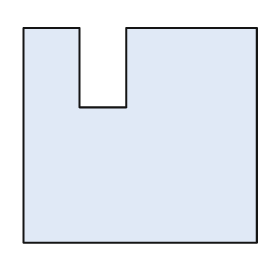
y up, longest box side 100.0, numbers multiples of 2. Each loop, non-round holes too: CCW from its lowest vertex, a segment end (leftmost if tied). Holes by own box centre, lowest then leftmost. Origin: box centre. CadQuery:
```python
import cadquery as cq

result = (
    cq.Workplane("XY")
    .moveTo(-50.0, -46.0)
    .lineTo(50.0, -46.0)
    .lineTo(50.0, 46.0)
    .lineTo(-6.0, 46.0)
    .lineTo(-6.0, 12.0)
    .lineTo(-26.0, 12.0)
    .lineTo(-26.0, 46.0)
    .lineTo(-50.0, 46.0)
    .close()
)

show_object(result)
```